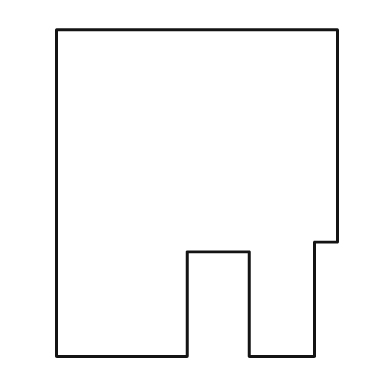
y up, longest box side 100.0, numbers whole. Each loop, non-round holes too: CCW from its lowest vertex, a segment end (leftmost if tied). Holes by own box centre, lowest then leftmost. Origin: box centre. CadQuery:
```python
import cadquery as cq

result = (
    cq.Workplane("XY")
    .moveTo(-43.0, -50.0)
    .lineTo(-3.0, -50.0)
    .lineTo(-3.0, -18.0)
    .lineTo(16.0, -18.0)
    .lineTo(16.0, -50.0)
    .lineTo(36.0, -50.0)
    .lineTo(36.0, -15.0)
    .lineTo(43.0, -15.0)
    .lineTo(43.0, 50.0)
    .lineTo(-43.0, 50.0)
    .close()
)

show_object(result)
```